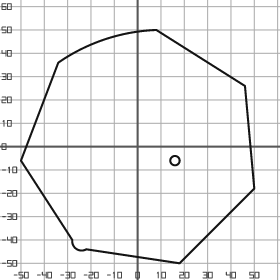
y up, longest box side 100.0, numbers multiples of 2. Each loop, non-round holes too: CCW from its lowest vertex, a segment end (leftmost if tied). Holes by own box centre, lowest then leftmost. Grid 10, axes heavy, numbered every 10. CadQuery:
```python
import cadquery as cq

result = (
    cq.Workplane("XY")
    .moveTo(18.0, -50.0)
    .lineTo(50.0, -18.0)
    .lineTo(46.0, 26.0)
    .lineTo(8.0, 50.0)
    .threePointArc((-14.0, 46.0), (-34.0, 36.0))
    .lineTo(-50.0, -6.0)
    .lineTo(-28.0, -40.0)
    .threePointArc((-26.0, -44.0), (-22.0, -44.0))
    .close()
    .moveTo(16.0, -6.0)
    .circle(2.0)
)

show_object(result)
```